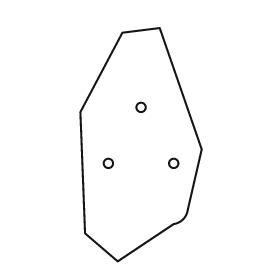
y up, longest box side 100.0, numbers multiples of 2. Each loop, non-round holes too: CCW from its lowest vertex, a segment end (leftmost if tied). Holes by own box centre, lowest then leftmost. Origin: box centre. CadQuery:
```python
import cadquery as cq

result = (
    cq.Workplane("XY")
    .moveTo(-10.0, -50.0)
    .lineTo(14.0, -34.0)
    .threePointArc((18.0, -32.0), (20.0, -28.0))
    .lineTo(26.0, -2.0)
    .lineTo(8.0, 50.0)
    .lineTo(-8.0, 48.0)
    .lineTo(-26.0, 14.0)
    .lineTo(-24.0, -38.0)
    .close()
    .moveTo(-14.0, -8.0)
    .circle(2.0)
    .moveTo(14.0, -8.0)
    .circle(2.0)
    .moveTo(0.0, 16.0)
    .circle(2.0)
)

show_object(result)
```